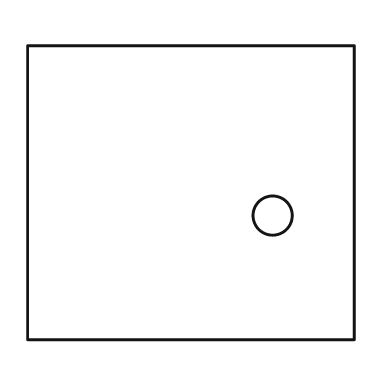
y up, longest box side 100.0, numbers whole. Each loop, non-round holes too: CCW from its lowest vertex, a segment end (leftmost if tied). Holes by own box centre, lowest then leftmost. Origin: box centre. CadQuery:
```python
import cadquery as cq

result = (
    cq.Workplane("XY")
    .moveTo(-50.0, -45.0)
    .lineTo(50.0, -45.0)
    .lineTo(50.0, 45.0)
    .lineTo(-50.0, 45.0)
    .close()
    .moveTo(25.0, -7.0)
    .circle(6.0)
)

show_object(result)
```